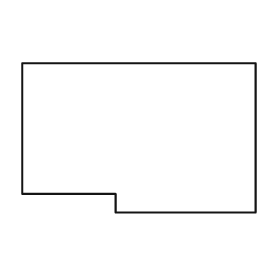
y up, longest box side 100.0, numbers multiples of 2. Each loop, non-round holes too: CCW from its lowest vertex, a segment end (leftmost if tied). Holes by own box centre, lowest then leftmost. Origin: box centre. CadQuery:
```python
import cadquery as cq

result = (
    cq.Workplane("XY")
    .moveTo(-10.0, -32.0)
    .lineTo(50.0, -32.0)
    .lineTo(50.0, 32.0)
    .lineTo(-50.0, 32.0)
    .lineTo(-50.0, -24.0)
    .lineTo(-10.0, -24.0)
    .close()
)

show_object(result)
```